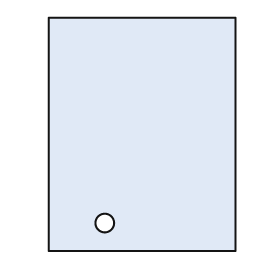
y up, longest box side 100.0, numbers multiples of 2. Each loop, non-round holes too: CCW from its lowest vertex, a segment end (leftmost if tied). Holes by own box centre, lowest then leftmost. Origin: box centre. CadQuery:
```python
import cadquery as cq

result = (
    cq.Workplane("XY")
    .moveTo(-40.0, -50.0)
    .lineTo(40.0, -50.0)
    .lineTo(40.0, 50.0)
    .lineTo(-40.0, 50.0)
    .close()
    .moveTo(-16.0, -38.0)
    .circle(4.0)
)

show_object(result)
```